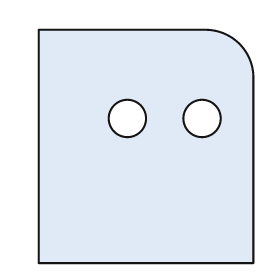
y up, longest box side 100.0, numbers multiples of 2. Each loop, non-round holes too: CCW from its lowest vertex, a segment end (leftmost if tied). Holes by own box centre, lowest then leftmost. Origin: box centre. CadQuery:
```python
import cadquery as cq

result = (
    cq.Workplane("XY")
    .moveTo(-46.0, -50.0)
    .lineTo(46.0, -50.0)
    .lineTo(46.0, 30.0)
    .threePointArc((40.0, 44.0), (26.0, 50.0))
    .lineTo(-46.0, 50.0)
    .close()
    .moveTo(-8.0, 12.0)
    .circle(8.0)
    .moveTo(24.0, 12.0)
    .circle(8.0)
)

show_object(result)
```